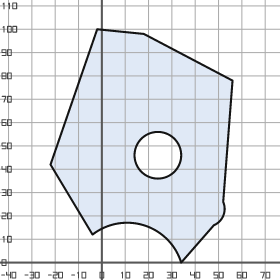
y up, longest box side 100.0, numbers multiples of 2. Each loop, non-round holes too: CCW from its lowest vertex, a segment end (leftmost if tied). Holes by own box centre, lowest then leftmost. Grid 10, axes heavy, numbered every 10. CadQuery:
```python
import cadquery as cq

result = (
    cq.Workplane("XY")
    .moveTo(34.0, 0.0)
    .lineTo(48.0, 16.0)
    .threePointArc((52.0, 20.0), (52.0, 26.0))
    .lineTo(56.0, 78.0)
    .lineTo(18.0, 98.0)
    .lineTo(-2.0, 100.0)
    .lineTo(-22.0, 42.0)
    .lineTo(-4.0, 12.0)
    .threePointArc((18.0, 16.0), (34.0, 0.0))
    .close()
    .moveTo(24.0, 46.0)
    .circle(10.0)
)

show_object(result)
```